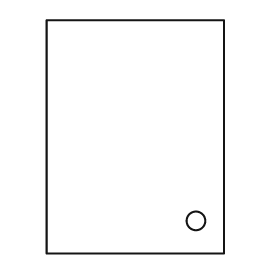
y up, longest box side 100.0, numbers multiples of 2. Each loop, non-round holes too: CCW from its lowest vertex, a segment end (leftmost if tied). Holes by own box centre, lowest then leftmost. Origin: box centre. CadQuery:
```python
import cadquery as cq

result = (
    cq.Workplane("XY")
    .moveTo(-38.0, -50.0)
    .lineTo(38.0, -50.0)
    .lineTo(38.0, 50.0)
    .lineTo(-38.0, 50.0)
    .close()
    .moveTo(26.0, -36.0)
    .circle(4.0)
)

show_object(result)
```